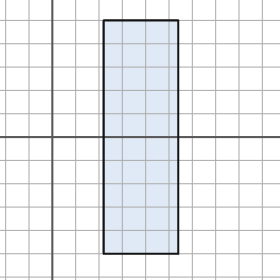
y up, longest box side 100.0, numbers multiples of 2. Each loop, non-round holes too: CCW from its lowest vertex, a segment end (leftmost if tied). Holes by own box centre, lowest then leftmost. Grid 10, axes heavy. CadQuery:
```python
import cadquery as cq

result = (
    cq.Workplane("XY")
    .moveTo(22.0, -50.0)
    .lineTo(54.0, -50.0)
    .lineTo(54.0, 50.0)
    .lineTo(22.0, 50.0)
    .close()
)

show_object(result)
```